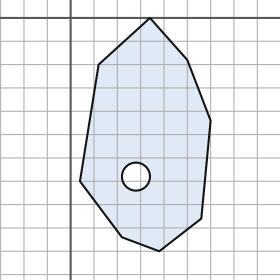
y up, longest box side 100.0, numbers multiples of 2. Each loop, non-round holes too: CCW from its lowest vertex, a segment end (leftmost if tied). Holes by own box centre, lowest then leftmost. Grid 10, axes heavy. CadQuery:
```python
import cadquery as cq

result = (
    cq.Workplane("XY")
    .moveTo(38.0, -100.0)
    .lineTo(56.0, -86.0)
    .lineTo(60.0, -44.0)
    .lineTo(50.0, -18.0)
    .lineTo(34.0, 0.0)
    .lineTo(12.0, -20.0)
    .lineTo(4.0, -70.0)
    .lineTo(22.0, -94.0)
    .close()
    .moveTo(28.0, -68.0)
    .circle(6.0)
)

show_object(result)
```